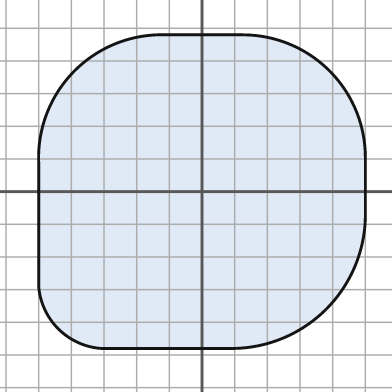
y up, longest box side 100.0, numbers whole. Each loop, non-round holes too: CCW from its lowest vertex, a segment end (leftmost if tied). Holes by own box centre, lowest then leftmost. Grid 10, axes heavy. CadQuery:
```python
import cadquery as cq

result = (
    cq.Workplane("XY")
    .moveTo(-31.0, -48.0)
    .lineTo(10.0, -48.0)
    .threePointArc((38.0, -36.0), (50.0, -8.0))
    .lineTo(50.0, 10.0)
    .threePointArc((39.0, 37.0), (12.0, 48.0))
    .lineTo(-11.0, 48.0)
    .threePointArc((-39.0, 37.0), (-50.0, 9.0))
    .lineTo(-50.0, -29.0)
    .threePointArc((-44.0, -42.0), (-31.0, -48.0))
    .close()
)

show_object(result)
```